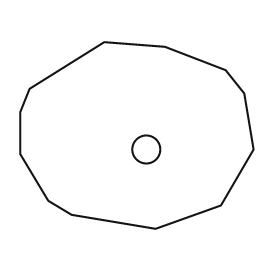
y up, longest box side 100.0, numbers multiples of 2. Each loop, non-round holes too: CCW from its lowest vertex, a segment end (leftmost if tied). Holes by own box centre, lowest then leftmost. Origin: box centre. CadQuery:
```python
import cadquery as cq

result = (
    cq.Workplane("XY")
    .moveTo(8.0, -40.0)
    .lineTo(36.0, -30.0)
    .lineTo(50.0, -6.0)
    .lineTo(46.0, 18.0)
    .lineTo(38.0, 28.0)
    .lineTo(12.0, 38.0)
    .lineTo(-14.0, 40.0)
    .lineTo(-46.0, 20.0)
    .lineTo(-50.0, 10.0)
    .lineTo(-50.0, -8.0)
    .lineTo(-38.0, -28.0)
    .lineTo(-28.0, -34.0)
    .close()
    .moveTo(4.0, -6.0)
    .circle(6.0)
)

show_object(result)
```